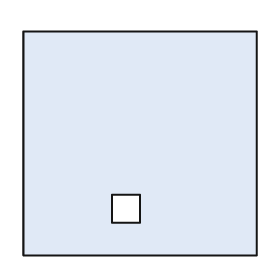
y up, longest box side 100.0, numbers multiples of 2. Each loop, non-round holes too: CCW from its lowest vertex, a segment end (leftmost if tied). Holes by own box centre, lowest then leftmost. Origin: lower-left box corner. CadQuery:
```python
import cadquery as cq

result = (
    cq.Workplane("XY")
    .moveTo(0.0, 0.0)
    .lineTo(100.0, 0.0)
    .lineTo(100.0, 96.0)
    .lineTo(0.0, 96.0)
    .close()
    .moveTo(38.0, 14.0)
    .lineTo(50.0, 14.0)
    .lineTo(50.0, 26.0)
    .lineTo(38.0, 26.0)
    .close()
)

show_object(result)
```